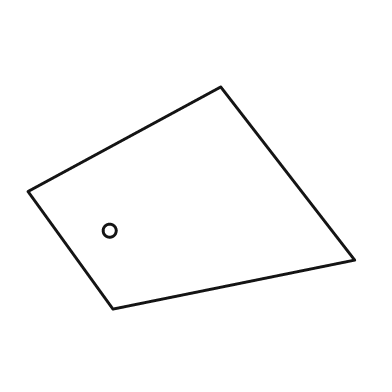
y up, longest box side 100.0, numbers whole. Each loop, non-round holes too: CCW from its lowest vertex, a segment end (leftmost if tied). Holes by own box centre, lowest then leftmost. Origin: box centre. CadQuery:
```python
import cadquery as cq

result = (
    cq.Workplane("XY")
    .moveTo(-24.0, -34.0)
    .lineTo(50.0, -19.0)
    .lineTo(9.0, 34.0)
    .lineTo(-50.0, 2.0)
    .close()
    .moveTo(-25.0, -10.0)
    .circle(2.0)
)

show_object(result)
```